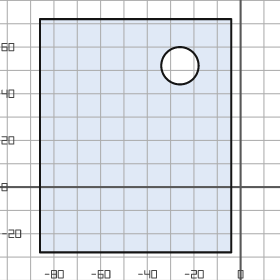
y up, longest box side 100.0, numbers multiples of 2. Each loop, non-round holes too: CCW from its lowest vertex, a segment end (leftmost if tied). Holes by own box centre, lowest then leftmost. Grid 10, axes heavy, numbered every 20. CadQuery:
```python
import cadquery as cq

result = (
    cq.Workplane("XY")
    .moveTo(-86.0, -28.0)
    .lineTo(-4.0, -28.0)
    .lineTo(-4.0, 72.0)
    .lineTo(-86.0, 72.0)
    .close()
    .moveTo(-26.0, 52.0)
    .circle(8.0)
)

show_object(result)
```